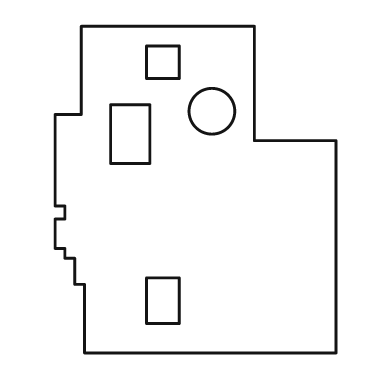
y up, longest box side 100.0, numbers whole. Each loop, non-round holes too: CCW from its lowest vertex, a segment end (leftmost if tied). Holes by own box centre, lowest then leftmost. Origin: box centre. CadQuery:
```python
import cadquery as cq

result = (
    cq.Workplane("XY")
    .moveTo(-34.0, -50.0)
    .lineTo(43.0, -50.0)
    .lineTo(43.0, 15.0)
    .lineTo(18.0, 15.0)
    .lineTo(18.0, 50.0)
    .lineTo(-35.0, 50.0)
    .lineTo(-35.0, 23.0)
    .lineTo(-43.0, 23.0)
    .lineTo(-43.0, -5.0)
    .lineTo(-40.0, -5.0)
    .lineTo(-40.0, -9.0)
    .lineTo(-43.0, -9.0)
    .lineTo(-43.0, -18.0)
    .lineTo(-40.0, -18.0)
    .lineTo(-40.0, -21.0)
    .lineTo(-37.0, -21.0)
    .lineTo(-37.0, -29.0)
    .lineTo(-34.0, -29.0)
    .close()
    .moveTo(-15.0, -41.0)
    .lineTo(-5.0, -41.0)
    .lineTo(-5.0, -27.0)
    .lineTo(-15.0, -27.0)
    .close()
    .moveTo(-26.0, 8.0)
    .lineTo(-14.0, 8.0)
    .lineTo(-14.0, 26.0)
    .lineTo(-26.0, 26.0)
    .close()
    .moveTo(5.0, 24.0)
    .circle(7.0)
    .moveTo(-15.0, 34.0)
    .lineTo(-5.0, 34.0)
    .lineTo(-5.0, 44.0)
    .lineTo(-15.0, 44.0)
    .close()
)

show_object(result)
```